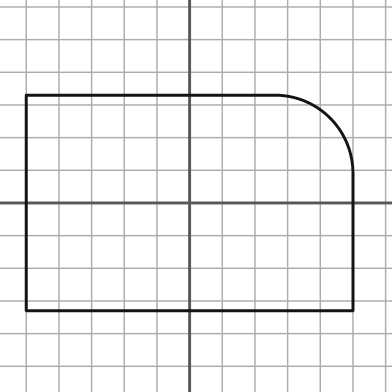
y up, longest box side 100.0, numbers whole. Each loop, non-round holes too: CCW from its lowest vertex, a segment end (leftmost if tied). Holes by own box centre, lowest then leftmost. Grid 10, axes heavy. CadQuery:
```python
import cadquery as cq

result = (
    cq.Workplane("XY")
    .moveTo(-50.0, -33.0)
    .lineTo(50.0, -33.0)
    .lineTo(50.0, 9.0)
    .threePointArc((43.0, 26.0), (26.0, 33.0))
    .lineTo(-50.0, 33.0)
    .close()
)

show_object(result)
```